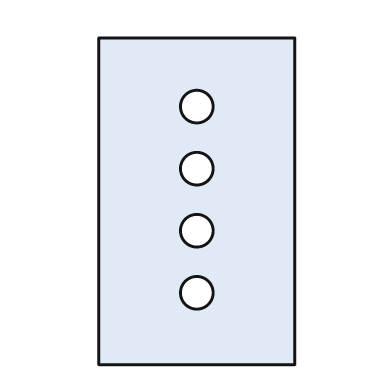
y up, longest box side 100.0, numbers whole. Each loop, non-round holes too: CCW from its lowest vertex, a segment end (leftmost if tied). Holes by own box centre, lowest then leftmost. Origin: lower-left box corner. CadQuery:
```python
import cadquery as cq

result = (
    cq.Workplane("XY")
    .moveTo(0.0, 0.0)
    .lineTo(60.0, 0.0)
    .lineTo(60.0, 100.0)
    .lineTo(0.0, 100.0)
    .close()
    .moveTo(30.0, 22.0)
    .circle(5.0)
    .moveTo(30.0, 41.0)
    .circle(5.0)
    .moveTo(30.0, 60.0)
    .circle(5.0)
    .moveTo(30.0, 79.0)
    .circle(5.0)
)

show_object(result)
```